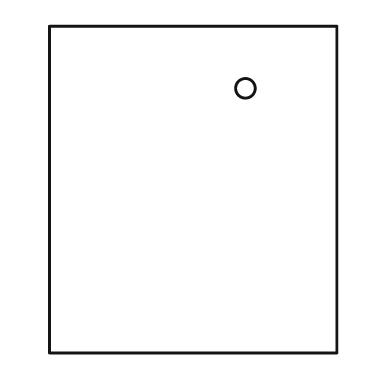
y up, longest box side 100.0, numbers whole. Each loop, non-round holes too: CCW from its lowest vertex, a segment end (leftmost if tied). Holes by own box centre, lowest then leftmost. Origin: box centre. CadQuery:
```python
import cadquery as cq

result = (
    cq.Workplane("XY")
    .moveTo(-44.0, -50.0)
    .lineTo(44.0, -50.0)
    .lineTo(44.0, 50.0)
    .lineTo(-44.0, 50.0)
    .close()
    .moveTo(16.0, 31.0)
    .circle(3.0)
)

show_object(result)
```